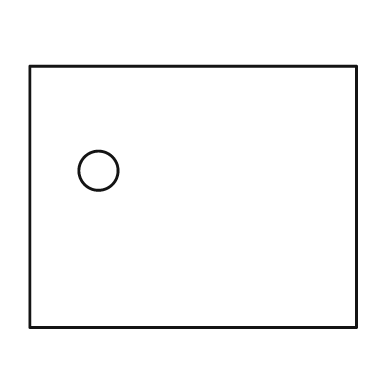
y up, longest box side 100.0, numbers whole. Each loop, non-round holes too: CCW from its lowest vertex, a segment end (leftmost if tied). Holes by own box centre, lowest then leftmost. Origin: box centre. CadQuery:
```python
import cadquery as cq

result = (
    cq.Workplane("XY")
    .moveTo(-50.0, -40.0)
    .lineTo(50.0, -40.0)
    .lineTo(50.0, 40.0)
    .lineTo(-50.0, 40.0)
    .close()
    .moveTo(-29.0, 8.0)
    .circle(6.0)
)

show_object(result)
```